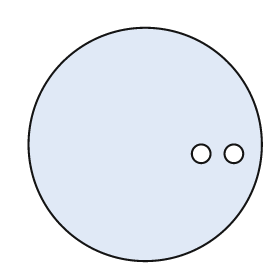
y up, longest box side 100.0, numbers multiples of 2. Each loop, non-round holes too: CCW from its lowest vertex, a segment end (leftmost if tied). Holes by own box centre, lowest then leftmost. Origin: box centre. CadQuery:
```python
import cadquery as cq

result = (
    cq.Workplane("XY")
    .moveTo(0.0, 0.0)
    .circle(50.0)
    .moveTo(24.0, -4.0)
    .circle(4.0)
    .moveTo(38.0, -4.0)
    .circle(4.0)
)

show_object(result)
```